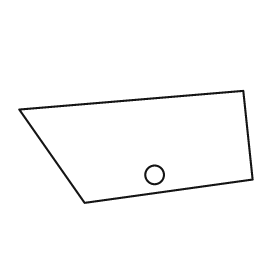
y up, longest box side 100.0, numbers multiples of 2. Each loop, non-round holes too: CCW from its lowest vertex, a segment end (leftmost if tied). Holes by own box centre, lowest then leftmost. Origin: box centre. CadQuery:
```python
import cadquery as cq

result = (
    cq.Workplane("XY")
    .moveTo(-22.0, -24.0)
    .lineTo(50.0, -14.0)
    .lineTo(46.0, 24.0)
    .lineTo(-50.0, 16.0)
    .close()
    .moveTo(8.0, -12.0)
    .circle(4.0)
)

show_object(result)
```